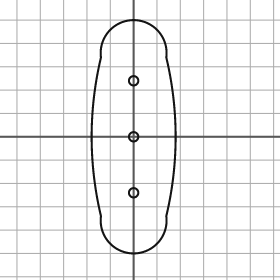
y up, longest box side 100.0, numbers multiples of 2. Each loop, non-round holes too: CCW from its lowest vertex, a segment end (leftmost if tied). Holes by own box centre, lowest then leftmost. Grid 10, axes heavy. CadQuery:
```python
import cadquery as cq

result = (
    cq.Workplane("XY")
    .moveTo(-14.0, -34.0)
    .threePointArc((0.0, -50.0), (14.0, -34.0))
    .threePointArc((18.0, 0.0), (14.0, 34.0))
    .threePointArc((0.0, 50.0), (-14.0, 34.0))
    .threePointArc((-18.0, 0.0), (-14.0, -34.0))
    .close()
    .moveTo(0.0, -24.0)
    .circle(2.0)
    .moveTo(0.0, 0.0)
    .circle(2.0)
    .moveTo(0.0, 24.0)
    .circle(2.0)
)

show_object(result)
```